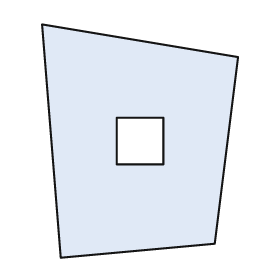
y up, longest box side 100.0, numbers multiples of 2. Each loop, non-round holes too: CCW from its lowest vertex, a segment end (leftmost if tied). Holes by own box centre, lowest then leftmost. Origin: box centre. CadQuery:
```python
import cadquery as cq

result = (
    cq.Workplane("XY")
    .moveTo(-34.0, -50.0)
    .lineTo(32.0, -44.0)
    .lineTo(42.0, 36.0)
    .lineTo(-42.0, 50.0)
    .close()
    .moveTo(-10.0, -10.0)
    .lineTo(10.0, -10.0)
    .lineTo(10.0, 10.0)
    .lineTo(-10.0, 10.0)
    .close()
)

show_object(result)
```